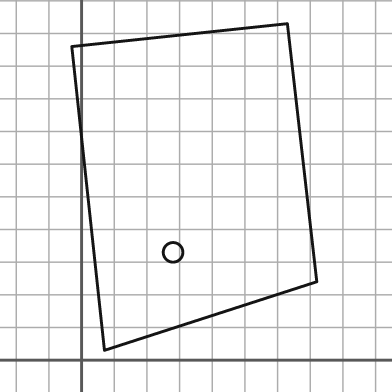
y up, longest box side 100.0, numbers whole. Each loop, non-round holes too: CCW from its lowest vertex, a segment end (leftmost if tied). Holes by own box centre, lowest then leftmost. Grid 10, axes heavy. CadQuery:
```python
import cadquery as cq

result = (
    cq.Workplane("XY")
    .moveTo(7.0, 3.0)
    .lineTo(72.0, 24.0)
    .lineTo(63.0, 103.0)
    .lineTo(-3.0, 96.0)
    .close()
    .moveTo(28.0, 33.0)
    .circle(3.0)
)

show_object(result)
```